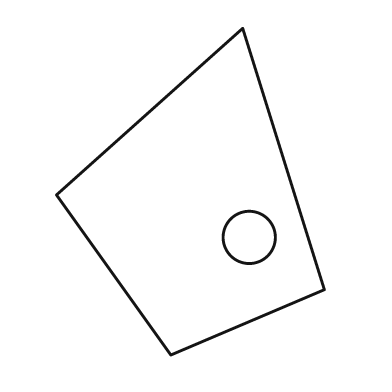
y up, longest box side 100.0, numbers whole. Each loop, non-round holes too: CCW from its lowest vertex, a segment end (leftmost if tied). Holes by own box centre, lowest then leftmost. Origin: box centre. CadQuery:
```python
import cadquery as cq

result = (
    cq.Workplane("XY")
    .moveTo(-6.0, -50.0)
    .lineTo(41.0, -30.0)
    .lineTo(16.0, 50.0)
    .lineTo(-41.0, -1.0)
    .close()
    .moveTo(18.0, -14.0)
    .circle(8.0)
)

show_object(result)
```